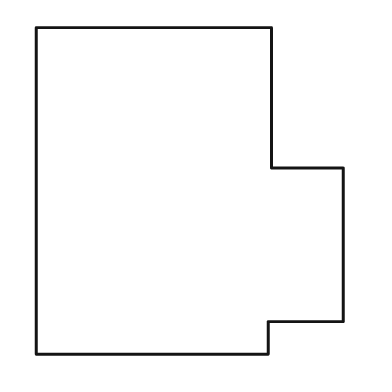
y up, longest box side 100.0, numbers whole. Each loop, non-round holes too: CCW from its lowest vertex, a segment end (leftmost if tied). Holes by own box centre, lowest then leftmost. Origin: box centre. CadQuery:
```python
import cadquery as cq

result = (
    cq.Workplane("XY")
    .moveTo(-47.0, -50.0)
    .lineTo(24.0, -50.0)
    .lineTo(24.0, -40.0)
    .lineTo(47.0, -40.0)
    .lineTo(47.0, 7.0)
    .lineTo(25.0, 7.0)
    .lineTo(25.0, 50.0)
    .lineTo(-47.0, 50.0)
    .close()
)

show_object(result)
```